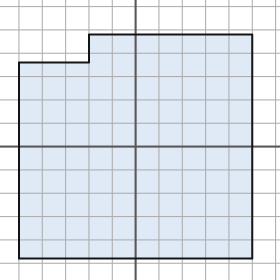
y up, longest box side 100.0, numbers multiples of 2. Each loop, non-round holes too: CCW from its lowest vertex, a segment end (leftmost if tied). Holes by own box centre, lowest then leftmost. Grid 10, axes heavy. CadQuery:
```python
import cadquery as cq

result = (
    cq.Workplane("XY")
    .moveTo(-50.0, -48.0)
    .lineTo(50.0, -48.0)
    .lineTo(50.0, 48.0)
    .lineTo(-20.0, 48.0)
    .lineTo(-20.0, 36.0)
    .lineTo(-50.0, 36.0)
    .close()
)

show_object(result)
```